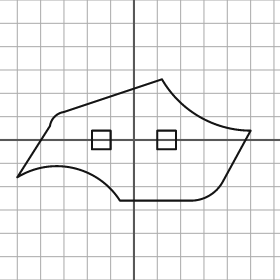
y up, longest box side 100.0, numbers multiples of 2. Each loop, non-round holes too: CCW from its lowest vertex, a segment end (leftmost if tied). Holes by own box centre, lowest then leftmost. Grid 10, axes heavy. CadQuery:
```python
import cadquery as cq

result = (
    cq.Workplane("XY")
    .moveTo(-6.0, -26.0)
    .lineTo(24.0, -26.0)
    .threePointArc((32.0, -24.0), (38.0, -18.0))
    .lineTo(50.0, 4.0)
    .threePointArc((28.0, 10.0), (12.0, 26.0))
    .lineTo(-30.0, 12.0)
    .threePointArc((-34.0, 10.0), (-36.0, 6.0))
    .lineTo(-50.0, -16.0)
    .threePointArc((-26.0, -12.0), (-6.0, -26.0))
    .close()
    .moveTo(-18.0, -4.0)
    .lineTo(-10.0, -4.0)
    .lineTo(-10.0, 4.0)
    .lineTo(-18.0, 4.0)
    .close()
    .moveTo(10.0, -4.0)
    .lineTo(18.0, -4.0)
    .lineTo(18.0, 4.0)
    .lineTo(10.0, 4.0)
    .close()
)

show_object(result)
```